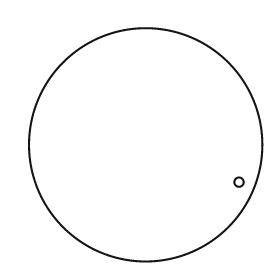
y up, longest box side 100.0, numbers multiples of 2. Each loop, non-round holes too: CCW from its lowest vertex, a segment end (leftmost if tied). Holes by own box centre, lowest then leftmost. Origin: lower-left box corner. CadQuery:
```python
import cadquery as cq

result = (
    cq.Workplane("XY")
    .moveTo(50.0, 50.0)
    .circle(50.0)
    .moveTo(90.0, 34.0)
    .circle(2.0)
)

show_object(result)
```